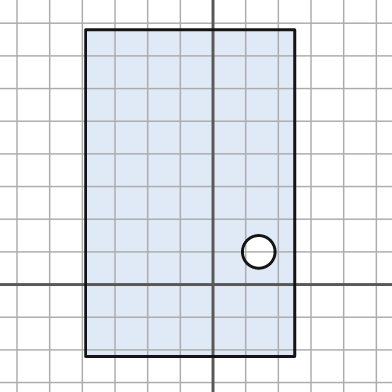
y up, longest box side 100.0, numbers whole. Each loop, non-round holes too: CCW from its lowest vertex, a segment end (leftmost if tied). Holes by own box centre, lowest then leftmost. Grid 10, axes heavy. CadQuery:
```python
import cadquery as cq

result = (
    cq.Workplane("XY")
    .moveTo(-39.0, -22.0)
    .lineTo(25.0, -22.0)
    .lineTo(25.0, 78.0)
    .lineTo(-39.0, 78.0)
    .close()
    .moveTo(14.0, 10.0)
    .circle(5.0)
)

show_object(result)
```